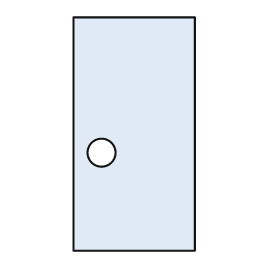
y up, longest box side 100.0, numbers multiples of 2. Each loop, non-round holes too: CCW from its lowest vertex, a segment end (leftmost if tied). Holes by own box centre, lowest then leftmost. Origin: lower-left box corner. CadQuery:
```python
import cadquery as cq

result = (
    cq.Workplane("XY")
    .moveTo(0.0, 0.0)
    .lineTo(52.0, 0.0)
    .lineTo(52.0, 100.0)
    .lineTo(0.0, 100.0)
    .close()
    .moveTo(12.0, 42.0)
    .circle(6.0)
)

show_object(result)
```